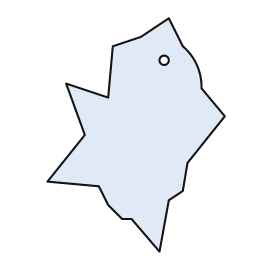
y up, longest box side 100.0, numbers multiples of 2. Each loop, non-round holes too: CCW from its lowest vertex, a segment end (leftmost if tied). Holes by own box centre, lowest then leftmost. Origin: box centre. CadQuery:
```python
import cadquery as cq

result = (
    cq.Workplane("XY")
    .moveTo(10.0, -50.0)
    .lineTo(14.0, -28.0)
    .lineTo(20.0, -24.0)
    .lineTo(22.0, -12.0)
    .lineTo(38.0, 8.0)
    .lineTo(28.0, 20.0)
    .threePointArc((26.0, 30.0), (20.0, 38.0))
    .lineTo(14.0, 50.0)
    .lineTo(2.0, 42.0)
    .lineTo(-10.0, 38.0)
    .lineTo(-12.0, 16.0)
    .lineTo(-30.0, 22.0)
    .lineTo(-22.0, 0.0)
    .lineTo(-38.0, -20.0)
    .lineTo(-16.0, -22.0)
    .lineTo(-12.0, -30.0)
    .lineTo(-6.0, -36.0)
    .lineTo(-2.0, -36.0)
    .close()
    .moveTo(12.0, 32.0)
    .circle(2.0)
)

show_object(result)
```